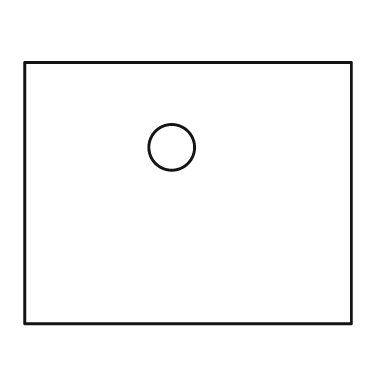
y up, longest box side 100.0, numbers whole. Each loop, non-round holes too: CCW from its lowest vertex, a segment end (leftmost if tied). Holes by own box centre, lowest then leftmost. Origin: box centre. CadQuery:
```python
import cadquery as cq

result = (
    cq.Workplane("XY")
    .moveTo(-50.0, -40.0)
    .lineTo(50.0, -40.0)
    .lineTo(50.0, 40.0)
    .lineTo(-50.0, 40.0)
    .close()
    .moveTo(-5.0, 14.0)
    .circle(7.0)
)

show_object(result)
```